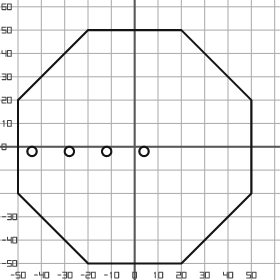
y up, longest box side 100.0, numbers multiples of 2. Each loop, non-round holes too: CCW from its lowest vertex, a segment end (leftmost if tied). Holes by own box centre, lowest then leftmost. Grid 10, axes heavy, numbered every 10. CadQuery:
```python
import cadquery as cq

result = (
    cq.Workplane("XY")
    .moveTo(-20.0, -50.0)
    .lineTo(20.0, -50.0)
    .lineTo(50.0, -20.0)
    .lineTo(50.0, 20.0)
    .lineTo(20.0, 50.0)
    .lineTo(-20.0, 50.0)
    .lineTo(-50.0, 20.0)
    .lineTo(-50.0, -20.0)
    .close()
    .moveTo(-44.0, -2.0)
    .circle(2.0)
    .moveTo(-28.0, -2.0)
    .circle(2.0)
    .moveTo(-12.0, -2.0)
    .circle(2.0)
    .moveTo(4.0, -2.0)
    .circle(2.0)
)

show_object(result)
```